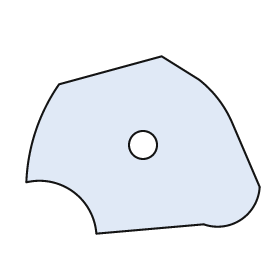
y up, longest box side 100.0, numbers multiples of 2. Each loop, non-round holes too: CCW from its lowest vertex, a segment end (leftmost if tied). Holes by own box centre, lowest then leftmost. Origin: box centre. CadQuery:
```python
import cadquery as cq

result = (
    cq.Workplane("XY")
    .moveTo(-20.0, -38.0)
    .lineTo(26.0, -34.0)
    .threePointArc((42.0, -32.0), (50.0, -18.0))
    .lineTo(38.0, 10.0)
    .threePointArc((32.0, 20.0), (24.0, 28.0))
    .lineTo(8.0, 38.0)
    .lineTo(-36.0, 26.0)
    .threePointArc((-46.0, 6.0), (-50.0, -16.0))
    .threePointArc((-30.0, -20.0), (-20.0, -38.0))
    .close()
    .moveTo(0.0, 0.0)
    .circle(6.0)
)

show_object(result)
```